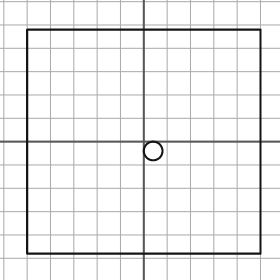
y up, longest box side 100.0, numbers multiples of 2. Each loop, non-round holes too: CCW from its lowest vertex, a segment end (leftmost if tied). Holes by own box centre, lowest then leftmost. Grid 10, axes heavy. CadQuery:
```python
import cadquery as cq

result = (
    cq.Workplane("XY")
    .moveTo(-50.0, -48.0)
    .lineTo(50.0, -48.0)
    .lineTo(50.0, 48.0)
    .lineTo(-50.0, 48.0)
    .close()
    .moveTo(4.0, -4.0)
    .circle(4.0)
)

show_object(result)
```